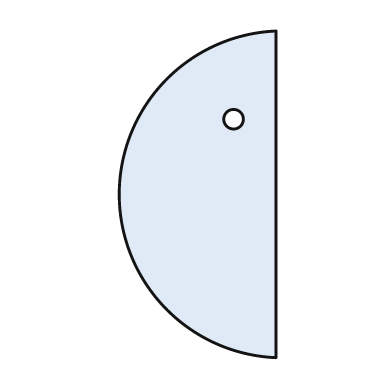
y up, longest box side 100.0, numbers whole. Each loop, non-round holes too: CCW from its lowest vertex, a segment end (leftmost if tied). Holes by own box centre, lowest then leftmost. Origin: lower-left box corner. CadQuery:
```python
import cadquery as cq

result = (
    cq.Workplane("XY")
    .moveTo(48.0, 0.0)
    .lineTo(48.0, 100.0)
    .threePointArc((0.0, 50.0), (48.0, 0.0))
    .close()
    .moveTo(35.0, 73.0)
    .circle(3.0)
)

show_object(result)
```